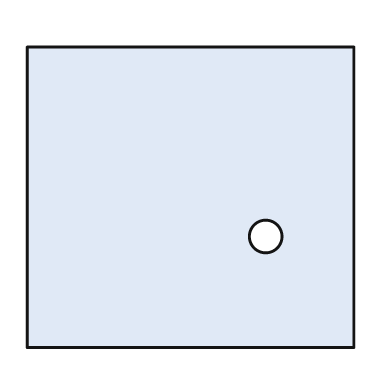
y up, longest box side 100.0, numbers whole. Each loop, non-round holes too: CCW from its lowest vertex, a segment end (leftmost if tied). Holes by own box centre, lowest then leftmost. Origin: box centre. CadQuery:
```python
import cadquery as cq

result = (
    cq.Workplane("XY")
    .moveTo(-50.0, -46.0)
    .lineTo(50.0, -46.0)
    .lineTo(50.0, 46.0)
    .lineTo(-50.0, 46.0)
    .close()
    .moveTo(23.0, -12.0)
    .circle(5.0)
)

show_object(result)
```